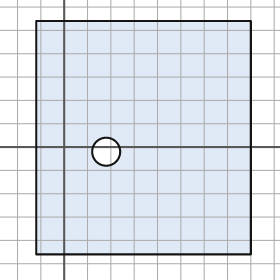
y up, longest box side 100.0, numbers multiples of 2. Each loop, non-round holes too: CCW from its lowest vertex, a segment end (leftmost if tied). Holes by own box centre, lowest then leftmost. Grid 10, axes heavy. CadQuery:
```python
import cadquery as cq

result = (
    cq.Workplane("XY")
    .moveTo(-12.0, -46.0)
    .lineTo(80.0, -46.0)
    .lineTo(80.0, 54.0)
    .lineTo(-12.0, 54.0)
    .close()
    .moveTo(18.0, -2.0)
    .circle(6.0)
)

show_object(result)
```